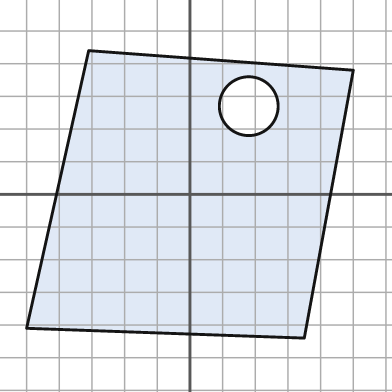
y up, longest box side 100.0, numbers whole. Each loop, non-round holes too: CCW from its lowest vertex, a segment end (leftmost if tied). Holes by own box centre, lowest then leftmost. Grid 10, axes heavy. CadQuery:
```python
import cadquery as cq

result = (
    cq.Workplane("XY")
    .moveTo(35.0, -44.0)
    .lineTo(50.0, 38.0)
    .lineTo(-31.0, 44.0)
    .lineTo(-50.0, -41.0)
    .close()
    .moveTo(18.0, 27.0)
    .circle(9.0)
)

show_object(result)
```